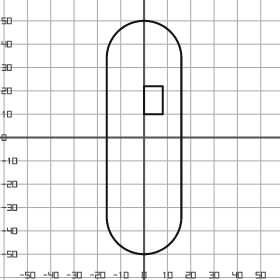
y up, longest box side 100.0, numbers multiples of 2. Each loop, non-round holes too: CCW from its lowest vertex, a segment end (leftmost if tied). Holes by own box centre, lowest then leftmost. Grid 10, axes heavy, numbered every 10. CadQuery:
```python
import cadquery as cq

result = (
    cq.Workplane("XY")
    .moveTo(-16.0, -34.0)
    .threePointArc((0.0, -50.0), (16.0, -34.0))
    .lineTo(16.0, 34.0)
    .threePointArc((0.0, 50.0), (-16.0, 34.0))
    .close()
    .moveTo(0.0, 10.0)
    .lineTo(8.0, 10.0)
    .lineTo(8.0, 22.0)
    .lineTo(0.0, 22.0)
    .close()
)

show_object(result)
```